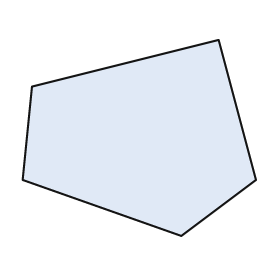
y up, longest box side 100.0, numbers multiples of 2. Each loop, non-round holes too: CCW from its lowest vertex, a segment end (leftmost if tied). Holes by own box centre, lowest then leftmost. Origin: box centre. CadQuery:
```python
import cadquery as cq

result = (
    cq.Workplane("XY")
    .moveTo(18.0, -42.0)
    .lineTo(50.0, -18.0)
    .lineTo(34.0, 42.0)
    .lineTo(-46.0, 22.0)
    .lineTo(-50.0, -18.0)
    .close()
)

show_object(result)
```